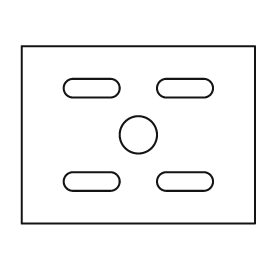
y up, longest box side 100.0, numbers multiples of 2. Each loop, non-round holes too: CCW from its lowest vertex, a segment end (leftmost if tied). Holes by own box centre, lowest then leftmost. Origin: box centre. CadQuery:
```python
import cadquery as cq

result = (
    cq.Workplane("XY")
    .moveTo(-50.0, -38.0)
    .lineTo(50.0, -38.0)
    .lineTo(50.0, 38.0)
    .lineTo(-50.0, 38.0)
    .close()
    .moveTo(-28.0, -24.0)
    .lineTo(-12.0, -24.0)
    .threePointArc((-8.0, -20.0), (-12.0, -16.0))
    .lineTo(-28.0, -16.0)
    .threePointArc((-32.0, -20.0), (-28.0, -24.0))
    .close()
    .moveTo(12.0, -24.0)
    .lineTo(28.0, -24.0)
    .threePointArc((32.0, -20.0), (28.0, -16.0))
    .lineTo(12.0, -16.0)
    .threePointArc((8.0, -20.0), (12.0, -24.0))
    .close()
    .moveTo(0.0, 0.0)
    .circle(8.0)
    .moveTo(-28.0, 16.0)
    .lineTo(-12.0, 16.0)
    .threePointArc((-8.0, 20.0), (-12.0, 24.0))
    .lineTo(-28.0, 24.0)
    .threePointArc((-32.0, 20.0), (-28.0, 16.0))
    .close()
    .moveTo(12.0, 16.0)
    .lineTo(28.0, 16.0)
    .threePointArc((32.0, 20.0), (28.0, 24.0))
    .lineTo(12.0, 24.0)
    .threePointArc((8.0, 20.0), (12.0, 16.0))
    .close()
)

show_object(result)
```